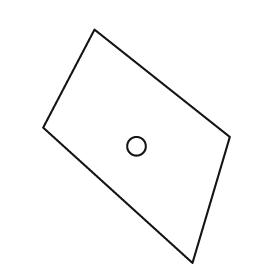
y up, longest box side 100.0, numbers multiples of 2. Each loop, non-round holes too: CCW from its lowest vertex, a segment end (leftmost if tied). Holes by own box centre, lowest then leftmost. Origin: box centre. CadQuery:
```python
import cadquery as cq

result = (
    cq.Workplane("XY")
    .moveTo(24.0, -50.0)
    .lineTo(40.0, 4.0)
    .lineTo(-18.0, 50.0)
    .lineTo(-40.0, 8.0)
    .close()
    .moveTo(0.0, 0.0)
    .circle(4.0)
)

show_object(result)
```